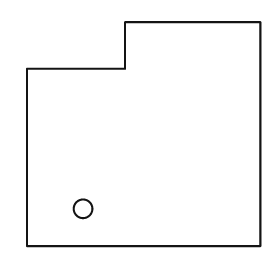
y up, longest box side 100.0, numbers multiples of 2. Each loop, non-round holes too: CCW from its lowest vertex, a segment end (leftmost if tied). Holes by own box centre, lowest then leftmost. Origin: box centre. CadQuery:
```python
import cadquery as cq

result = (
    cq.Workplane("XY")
    .moveTo(-50.0, -48.0)
    .lineTo(50.0, -48.0)
    .lineTo(50.0, 48.0)
    .lineTo(-8.0, 48.0)
    .lineTo(-8.0, 28.0)
    .lineTo(-50.0, 28.0)
    .close()
    .moveTo(-26.0, -32.0)
    .circle(4.0)
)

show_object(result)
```